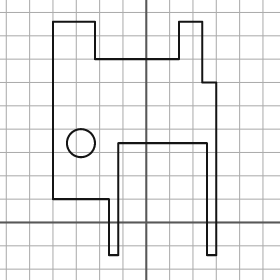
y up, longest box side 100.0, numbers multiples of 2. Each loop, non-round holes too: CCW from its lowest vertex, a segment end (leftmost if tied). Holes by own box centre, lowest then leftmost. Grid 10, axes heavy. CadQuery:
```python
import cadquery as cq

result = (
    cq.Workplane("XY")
    .moveTo(-16.0, -14.0)
    .lineTo(-12.0, -14.0)
    .lineTo(-12.0, 34.0)
    .lineTo(26.0, 34.0)
    .lineTo(26.0, -14.0)
    .lineTo(30.0, -14.0)
    .lineTo(30.0, 60.0)
    .lineTo(24.0, 60.0)
    .lineTo(24.0, 86.0)
    .lineTo(14.0, 86.0)
    .lineTo(14.0, 70.0)
    .lineTo(-22.0, 70.0)
    .lineTo(-22.0, 86.0)
    .lineTo(-40.0, 86.0)
    .lineTo(-40.0, 10.0)
    .lineTo(-16.0, 10.0)
    .close()
    .moveTo(-28.0, 34.0)
    .circle(6.0)
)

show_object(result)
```